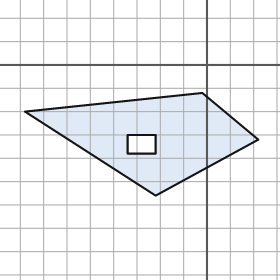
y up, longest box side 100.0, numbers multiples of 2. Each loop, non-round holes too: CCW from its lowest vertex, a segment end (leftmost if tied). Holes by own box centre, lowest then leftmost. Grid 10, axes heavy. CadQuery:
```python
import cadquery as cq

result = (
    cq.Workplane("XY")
    .moveTo(-22.0, -56.0)
    .lineTo(22.0, -32.0)
    .lineTo(-2.0, -12.0)
    .lineTo(-78.0, -20.0)
    .close()
    .moveTo(-34.0, -38.0)
    .lineTo(-22.0, -38.0)
    .lineTo(-22.0, -30.0)
    .lineTo(-34.0, -30.0)
    .close()
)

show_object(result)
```